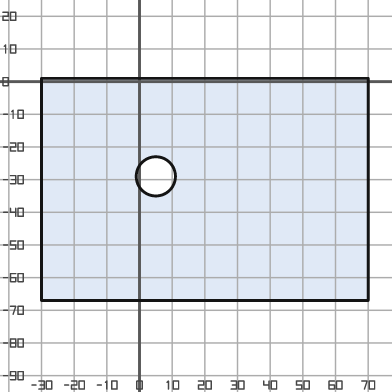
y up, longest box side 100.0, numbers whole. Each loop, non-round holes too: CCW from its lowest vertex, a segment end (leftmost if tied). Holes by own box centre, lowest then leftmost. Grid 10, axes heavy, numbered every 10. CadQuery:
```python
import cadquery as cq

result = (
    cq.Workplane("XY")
    .moveTo(-30.0, -67.0)
    .lineTo(70.0, -67.0)
    .lineTo(70.0, 1.0)
    .lineTo(-30.0, 1.0)
    .close()
    .moveTo(5.0, -29.0)
    .circle(6.0)
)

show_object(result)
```